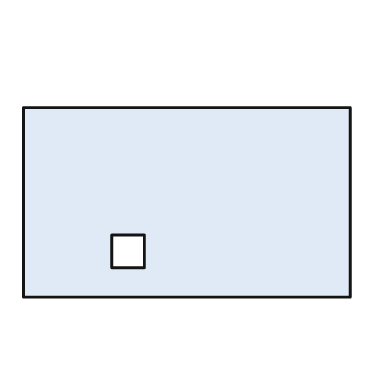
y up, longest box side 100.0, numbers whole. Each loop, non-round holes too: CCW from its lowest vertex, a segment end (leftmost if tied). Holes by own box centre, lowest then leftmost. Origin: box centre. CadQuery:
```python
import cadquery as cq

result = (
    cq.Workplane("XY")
    .moveTo(-50.0, -29.0)
    .lineTo(50.0, -29.0)
    .lineTo(50.0, 29.0)
    .lineTo(-50.0, 29.0)
    .close()
    .moveTo(-23.0, -20.0)
    .lineTo(-13.0, -20.0)
    .lineTo(-13.0, -10.0)
    .lineTo(-23.0, -10.0)
    .close()
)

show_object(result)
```